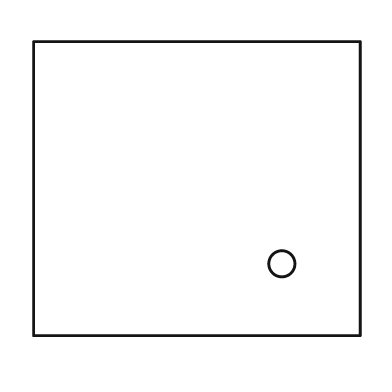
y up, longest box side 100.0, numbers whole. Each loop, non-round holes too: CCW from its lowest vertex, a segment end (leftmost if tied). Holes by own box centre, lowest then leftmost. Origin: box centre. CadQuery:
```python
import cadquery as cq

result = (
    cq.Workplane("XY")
    .moveTo(-50.0, -45.0)
    .lineTo(50.0, -45.0)
    .lineTo(50.0, 45.0)
    .lineTo(-50.0, 45.0)
    .close()
    .moveTo(26.0, -23.0)
    .circle(4.0)
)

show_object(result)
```